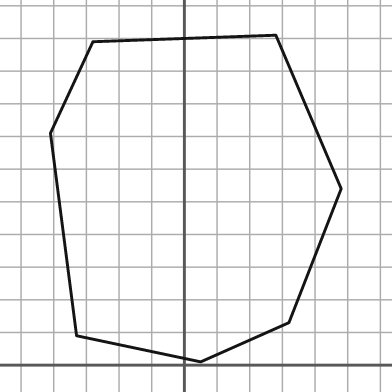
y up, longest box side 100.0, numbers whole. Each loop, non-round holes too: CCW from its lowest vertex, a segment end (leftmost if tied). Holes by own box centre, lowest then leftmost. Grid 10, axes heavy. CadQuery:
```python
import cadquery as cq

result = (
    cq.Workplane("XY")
    .moveTo(5.0, 1.0)
    .lineTo(32.0, 13.0)
    .lineTo(48.0, 54.0)
    .lineTo(28.0, 101.0)
    .lineTo(-28.0, 99.0)
    .lineTo(-41.0, 71.0)
    .lineTo(-33.0, 9.0)
    .close()
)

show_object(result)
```